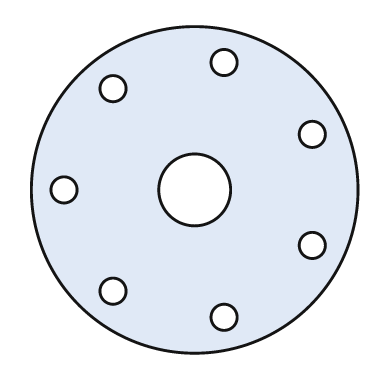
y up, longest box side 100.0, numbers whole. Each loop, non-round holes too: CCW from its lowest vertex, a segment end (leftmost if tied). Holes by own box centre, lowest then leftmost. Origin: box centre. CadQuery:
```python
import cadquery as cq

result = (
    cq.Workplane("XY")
    .moveTo(0.0, 0.0)
    .circle(50.0)
    .moveTo(9.0, -39.0)
    .circle(4.0)
    .moveTo(-25.0, -31.0)
    .circle(4.0)
    .moveTo(36.0, -17.0)
    .circle(4.0)
    .moveTo(-40.0, 0.0)
    .circle(4.0)
    .moveTo(0.0, 0.0)
    .circle(11.0)
    .moveTo(36.0, 17.0)
    .circle(4.0)
    .moveTo(-25.0, 31.0)
    .circle(4.0)
    .moveTo(9.0, 39.0)
    .circle(4.0)
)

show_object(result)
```